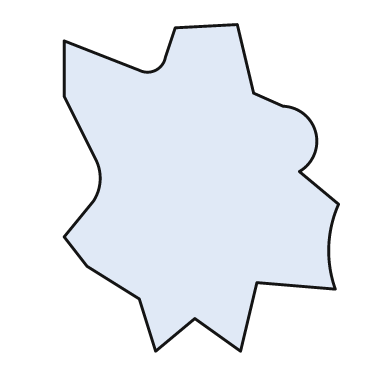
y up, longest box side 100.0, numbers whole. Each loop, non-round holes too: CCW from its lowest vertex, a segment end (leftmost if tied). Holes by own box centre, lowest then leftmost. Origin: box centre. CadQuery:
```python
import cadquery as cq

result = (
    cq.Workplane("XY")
    .moveTo(-14.0, -50.0)
    .lineTo(-2.0, -40.0)
    .lineTo(12.0, -50.0)
    .lineTo(17.0, -29.0)
    .lineTo(41.0, -31.0)
    .threePointArc((39.0, -18.0), (42.0, -5.0))
    .lineTo(30.0, 5.0)
    .threePointArc((35.0, 17.0), (25.0, 25.0))
    .lineTo(16.0, 29.0)
    .lineTo(11.0, 50.0)
    .lineTo(-8.0, 49.0)
    .lineTo(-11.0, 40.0)
    .threePointArc((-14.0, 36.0), (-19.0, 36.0))
    .lineTo(-42.0, 45.0)
    .lineTo(-42.0, 28.0)
    .lineTo(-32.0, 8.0)
    .threePointArc((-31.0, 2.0), (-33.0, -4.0))
    .lineTo(-42.0, -15.0)
    .lineTo(-35.0, -24.0)
    .lineTo(-19.0, -34.0)
    .close()
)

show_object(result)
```